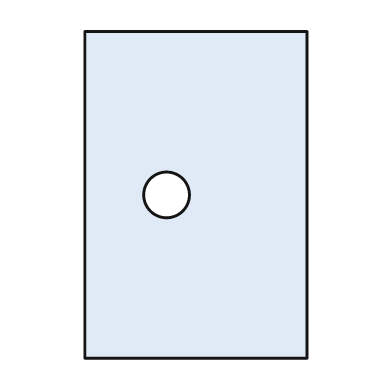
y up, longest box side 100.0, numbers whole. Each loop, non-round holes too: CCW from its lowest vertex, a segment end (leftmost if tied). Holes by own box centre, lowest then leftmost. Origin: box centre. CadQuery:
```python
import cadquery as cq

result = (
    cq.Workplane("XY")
    .moveTo(-34.0, -50.0)
    .lineTo(34.0, -50.0)
    .lineTo(34.0, 50.0)
    .lineTo(-34.0, 50.0)
    .close()
    .moveTo(-9.0, 0.0)
    .circle(7.0)
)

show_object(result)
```